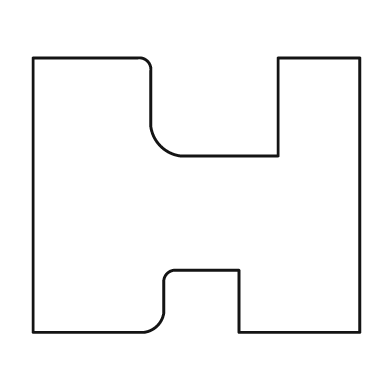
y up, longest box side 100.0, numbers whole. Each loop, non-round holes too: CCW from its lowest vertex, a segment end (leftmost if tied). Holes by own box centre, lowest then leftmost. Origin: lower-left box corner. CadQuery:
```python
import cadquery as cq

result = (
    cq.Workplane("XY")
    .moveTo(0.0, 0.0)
    .lineTo(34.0, 0.0)
    .threePointArc((38.0, 2.0), (40.0, 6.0))
    .lineTo(40.0, 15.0)
    .threePointArc((41.0, 18.0), (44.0, 19.0))
    .lineTo(63.0, 19.0)
    .lineTo(63.0, 0.0)
    .lineTo(100.0, 0.0)
    .lineTo(100.0, 84.0)
    .lineTo(75.0, 84.0)
    .lineTo(75.0, 54.0)
    .lineTo(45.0, 54.0)
    .threePointArc((39.0, 57.0), (36.0, 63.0))
    .lineTo(36.0, 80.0)
    .threePointArc((35.0, 83.0), (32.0, 84.0))
    .lineTo(0.0, 84.0)
    .close()
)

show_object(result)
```